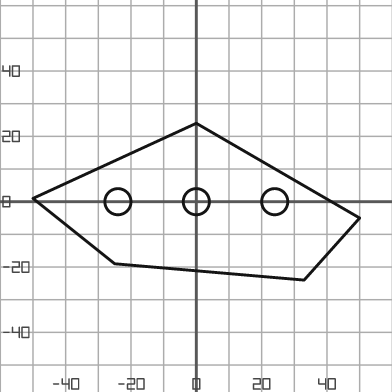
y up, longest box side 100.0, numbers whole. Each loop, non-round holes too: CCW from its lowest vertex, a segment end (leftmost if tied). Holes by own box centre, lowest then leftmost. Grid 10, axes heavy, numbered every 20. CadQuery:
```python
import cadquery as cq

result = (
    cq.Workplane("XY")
    .moveTo(33.0, -24.0)
    .lineTo(50.0, -5.0)
    .lineTo(0.0, 24.0)
    .lineTo(-50.0, 1.0)
    .lineTo(-25.0, -19.0)
    .close()
    .moveTo(-24.0, 0.0)
    .circle(4.0)
    .moveTo(0.0, 0.0)
    .circle(4.0)
    .moveTo(24.0, 0.0)
    .circle(4.0)
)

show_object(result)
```